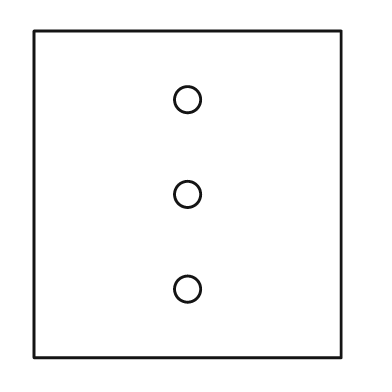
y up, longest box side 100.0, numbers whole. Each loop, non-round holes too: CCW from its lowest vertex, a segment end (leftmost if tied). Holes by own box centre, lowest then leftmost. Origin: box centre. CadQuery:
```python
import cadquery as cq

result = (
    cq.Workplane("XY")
    .moveTo(-47.0, -50.0)
    .lineTo(47.0, -50.0)
    .lineTo(47.0, 50.0)
    .lineTo(-47.0, 50.0)
    .close()
    .moveTo(0.0, -29.0)
    .circle(4.0)
    .moveTo(0.0, 0.0)
    .circle(4.0)
    .moveTo(0.0, 29.0)
    .circle(4.0)
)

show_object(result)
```